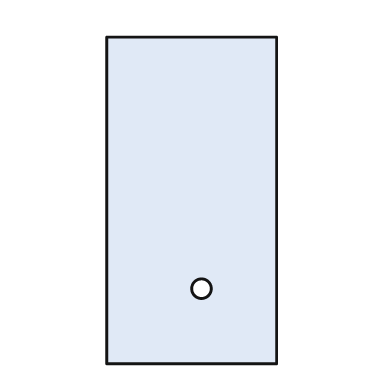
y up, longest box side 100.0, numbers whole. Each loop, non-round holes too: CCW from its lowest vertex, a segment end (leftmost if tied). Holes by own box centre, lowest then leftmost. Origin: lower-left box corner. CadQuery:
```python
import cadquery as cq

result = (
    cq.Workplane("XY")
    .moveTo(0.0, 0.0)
    .lineTo(52.0, 0.0)
    .lineTo(52.0, 100.0)
    .lineTo(0.0, 100.0)
    .close()
    .moveTo(29.0, 23.0)
    .circle(3.0)
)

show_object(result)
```